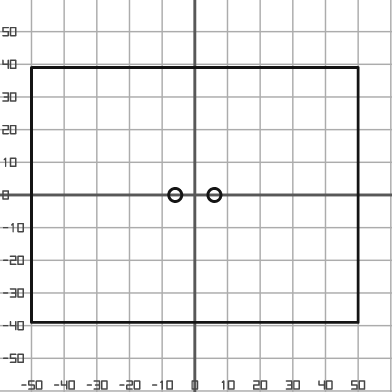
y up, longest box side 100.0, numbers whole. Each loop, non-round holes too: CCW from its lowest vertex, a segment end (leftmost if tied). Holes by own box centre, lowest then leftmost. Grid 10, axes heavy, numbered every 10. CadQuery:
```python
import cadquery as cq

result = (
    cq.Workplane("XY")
    .moveTo(-50.0, -39.0)
    .lineTo(50.0, -39.0)
    .lineTo(50.0, 39.0)
    .lineTo(-50.0, 39.0)
    .close()
    .moveTo(-6.0, 0.0)
    .circle(2.0)
    .moveTo(6.0, 0.0)
    .circle(2.0)
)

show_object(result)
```